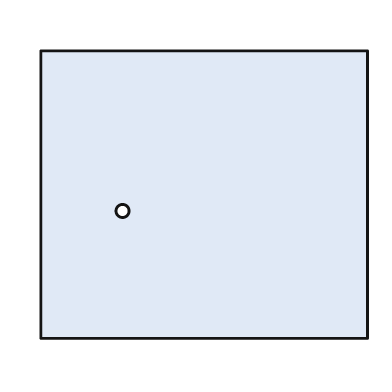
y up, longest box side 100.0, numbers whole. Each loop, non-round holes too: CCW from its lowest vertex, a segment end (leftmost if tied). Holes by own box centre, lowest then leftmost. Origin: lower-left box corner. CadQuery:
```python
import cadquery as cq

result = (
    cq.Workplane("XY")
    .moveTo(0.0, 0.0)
    .lineTo(100.0, 0.0)
    .lineTo(100.0, 88.0)
    .lineTo(0.0, 88.0)
    .close()
    .moveTo(25.0, 39.0)
    .circle(2.0)
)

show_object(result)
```